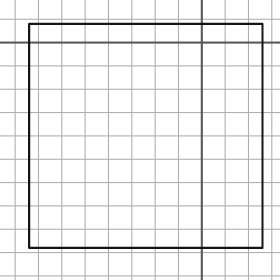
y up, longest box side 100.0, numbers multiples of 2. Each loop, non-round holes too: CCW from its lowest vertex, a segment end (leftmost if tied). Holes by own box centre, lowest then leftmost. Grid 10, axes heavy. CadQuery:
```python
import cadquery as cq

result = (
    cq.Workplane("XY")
    .moveTo(-74.0, -88.0)
    .lineTo(26.0, -88.0)
    .lineTo(26.0, 8.0)
    .lineTo(-74.0, 8.0)
    .close()
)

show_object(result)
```